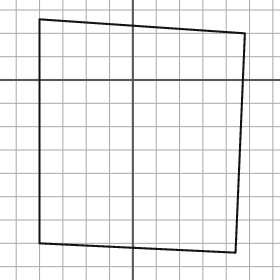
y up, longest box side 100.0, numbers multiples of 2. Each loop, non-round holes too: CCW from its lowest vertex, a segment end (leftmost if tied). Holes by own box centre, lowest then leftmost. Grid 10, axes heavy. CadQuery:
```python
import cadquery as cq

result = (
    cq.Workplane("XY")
    .moveTo(44.0, -74.0)
    .lineTo(48.0, 20.0)
    .lineTo(-40.0, 26.0)
    .lineTo(-40.0, -70.0)
    .close()
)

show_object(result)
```